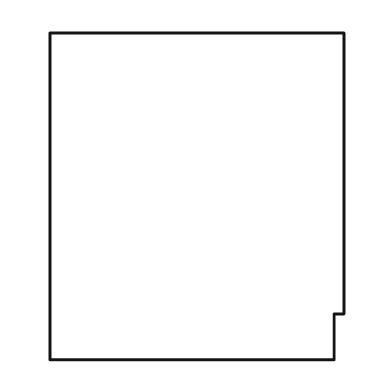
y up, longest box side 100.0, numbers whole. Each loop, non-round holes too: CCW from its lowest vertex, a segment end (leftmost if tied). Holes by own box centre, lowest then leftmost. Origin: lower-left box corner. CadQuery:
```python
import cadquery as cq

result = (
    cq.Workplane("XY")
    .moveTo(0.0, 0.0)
    .lineTo(87.0, 0.0)
    .lineTo(87.0, 14.0)
    .lineTo(90.0, 14.0)
    .lineTo(90.0, 100.0)
    .lineTo(0.0, 100.0)
    .close()
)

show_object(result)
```